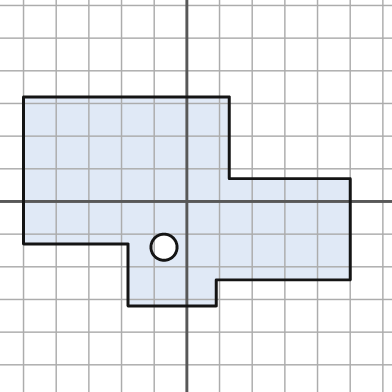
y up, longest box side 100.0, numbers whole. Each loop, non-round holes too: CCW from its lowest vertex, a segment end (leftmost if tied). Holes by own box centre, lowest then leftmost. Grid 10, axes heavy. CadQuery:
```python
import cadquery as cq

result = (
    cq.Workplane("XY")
    .moveTo(-18.0, -32.0)
    .lineTo(9.0, -32.0)
    .lineTo(9.0, -24.0)
    .lineTo(50.0, -24.0)
    .lineTo(50.0, 7.0)
    .lineTo(13.0, 7.0)
    .lineTo(13.0, 32.0)
    .lineTo(-50.0, 32.0)
    .lineTo(-50.0, -13.0)
    .lineTo(-18.0, -13.0)
    .close()
    .moveTo(-7.0, -14.0)
    .circle(4.0)
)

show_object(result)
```